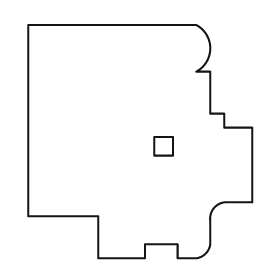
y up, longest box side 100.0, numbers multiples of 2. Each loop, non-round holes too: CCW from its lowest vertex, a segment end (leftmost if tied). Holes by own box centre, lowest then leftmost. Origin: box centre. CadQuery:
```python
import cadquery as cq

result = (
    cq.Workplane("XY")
    .moveTo(-18.0, -50.0)
    .lineTo(2.0, -50.0)
    .lineTo(2.0, -44.0)
    .lineTo(16.0, -44.0)
    .lineTo(16.0, -50.0)
    .lineTo(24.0, -50.0)
    .threePointArc((28.0, -48.0), (30.0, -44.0))
    .lineTo(30.0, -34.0)
    .threePointArc((32.0, -28.0), (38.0, -26.0))
    .lineTo(48.0, -26.0)
    .lineTo(48.0, 6.0)
    .lineTo(36.0, 6.0)
    .lineTo(36.0, 12.0)
    .lineTo(30.0, 12.0)
    .lineTo(30.0, 30.0)
    .lineTo(24.0, 30.0)
    .threePointArc((30.0, 40.0), (24.0, 50.0))
    .lineTo(-48.0, 50.0)
    .lineTo(-48.0, -32.0)
    .lineTo(-18.0, -32.0)
    .close()
    .moveTo(6.0, -6.0)
    .lineTo(14.0, -6.0)
    .lineTo(14.0, 2.0)
    .lineTo(6.0, 2.0)
    .close()
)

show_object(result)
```